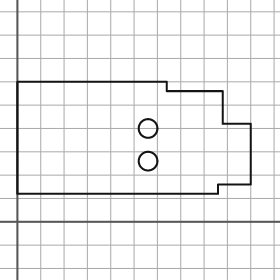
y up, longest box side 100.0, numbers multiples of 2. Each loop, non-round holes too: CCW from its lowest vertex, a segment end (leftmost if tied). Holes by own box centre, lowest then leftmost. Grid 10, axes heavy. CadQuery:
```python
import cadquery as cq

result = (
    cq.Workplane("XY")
    .moveTo(0.0, 12.0)
    .lineTo(86.0, 12.0)
    .lineTo(86.0, 16.0)
    .lineTo(100.0, 16.0)
    .lineTo(100.0, 42.0)
    .lineTo(88.0, 42.0)
    .lineTo(88.0, 56.0)
    .lineTo(64.0, 56.0)
    .lineTo(64.0, 60.0)
    .lineTo(0.0, 60.0)
    .close()
    .moveTo(56.0, 26.0)
    .circle(4.0)
    .moveTo(56.0, 40.0)
    .circle(4.0)
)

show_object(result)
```